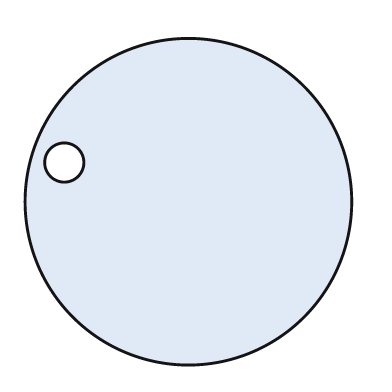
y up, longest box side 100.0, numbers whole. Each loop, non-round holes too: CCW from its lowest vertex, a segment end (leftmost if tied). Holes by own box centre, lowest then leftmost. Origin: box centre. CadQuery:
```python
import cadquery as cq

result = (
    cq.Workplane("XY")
    .moveTo(0.0, 0.0)
    .circle(50.0)
    .moveTo(-38.0, 12.0)
    .circle(6.0)
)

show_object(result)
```